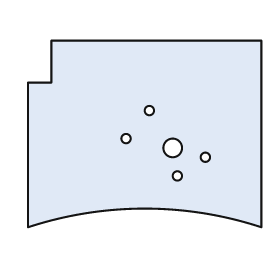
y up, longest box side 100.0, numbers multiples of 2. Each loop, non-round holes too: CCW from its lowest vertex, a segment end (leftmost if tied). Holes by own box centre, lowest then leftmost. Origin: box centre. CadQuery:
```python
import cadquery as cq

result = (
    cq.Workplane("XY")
    .moveTo(-50.0, -40.0)
    .threePointArc((0.0, -32.0), (50.0, -40.0))
    .lineTo(50.0, 40.0)
    .lineTo(-40.0, 40.0)
    .lineTo(-40.0, 22.0)
    .lineTo(-50.0, 22.0)
    .close()
    .moveTo(14.0, -18.0)
    .circle(2.0)
    .moveTo(26.0, -10.0)
    .circle(2.0)
    .moveTo(12.0, -6.0)
    .circle(4.0)
    .moveTo(-8.0, -2.0)
    .circle(2.0)
    .moveTo(2.0, 10.0)
    .circle(2.0)
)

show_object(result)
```